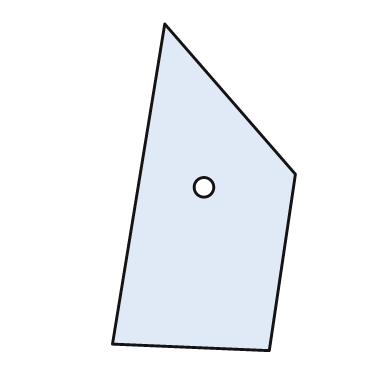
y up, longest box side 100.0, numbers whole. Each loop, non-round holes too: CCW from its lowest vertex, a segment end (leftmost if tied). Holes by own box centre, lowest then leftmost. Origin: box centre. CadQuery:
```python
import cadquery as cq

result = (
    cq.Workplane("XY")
    .moveTo(20.0, -50.0)
    .lineTo(28.0, 4.0)
    .lineTo(-12.0, 50.0)
    .lineTo(-28.0, -48.0)
    .close()
    .moveTo(0.0, 0.0)
    .circle(3.0)
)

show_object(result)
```